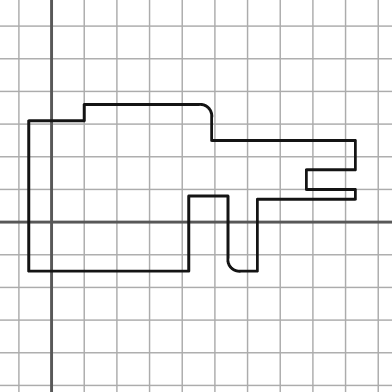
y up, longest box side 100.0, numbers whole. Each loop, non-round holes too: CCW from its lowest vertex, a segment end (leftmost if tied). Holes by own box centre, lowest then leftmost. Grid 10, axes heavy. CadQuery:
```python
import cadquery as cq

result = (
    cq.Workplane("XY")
    .moveTo(-7.0, -15.0)
    .lineTo(42.0, -15.0)
    .lineTo(42.0, 8.0)
    .lineTo(54.0, 8.0)
    .lineTo(54.0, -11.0)
    .threePointArc((55.0, -14.0), (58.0, -15.0))
    .lineTo(63.0, -15.0)
    .lineTo(63.0, 7.0)
    .lineTo(93.0, 7.0)
    .lineTo(93.0, 10.0)
    .lineTo(78.0, 10.0)
    .lineTo(78.0, 16.0)
    .lineTo(93.0, 16.0)
    .lineTo(93.0, 25.0)
    .lineTo(49.0, 25.0)
    .lineTo(49.0, 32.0)
    .threePointArc((48.0, 35.0), (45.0, 36.0))
    .lineTo(10.0, 36.0)
    .lineTo(10.0, 31.0)
    .lineTo(-7.0, 31.0)
    .close()
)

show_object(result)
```